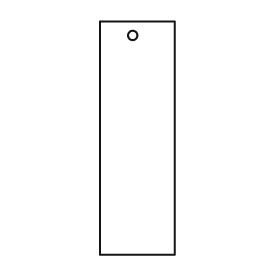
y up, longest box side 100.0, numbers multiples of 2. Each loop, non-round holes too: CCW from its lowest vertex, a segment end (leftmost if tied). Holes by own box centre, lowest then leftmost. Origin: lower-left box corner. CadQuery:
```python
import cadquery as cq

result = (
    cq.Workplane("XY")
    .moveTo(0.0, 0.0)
    .lineTo(32.0, 0.0)
    .lineTo(32.0, 100.0)
    .lineTo(0.0, 100.0)
    .close()
    .moveTo(14.0, 94.0)
    .circle(2.0)
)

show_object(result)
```